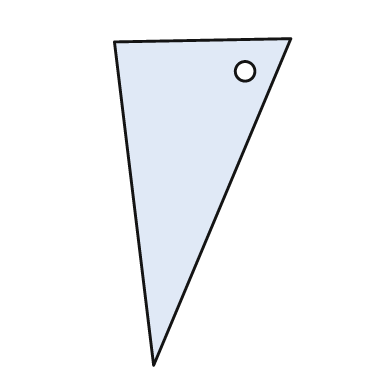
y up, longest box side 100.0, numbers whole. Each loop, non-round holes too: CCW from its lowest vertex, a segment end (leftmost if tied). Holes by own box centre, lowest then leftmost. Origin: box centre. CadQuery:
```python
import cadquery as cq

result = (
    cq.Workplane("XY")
    .moveTo(-15.0, -50.0)
    .lineTo(27.0, 50.0)
    .lineTo(-27.0, 49.0)
    .close()
    .moveTo(13.0, 40.0)
    .circle(3.0)
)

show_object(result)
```